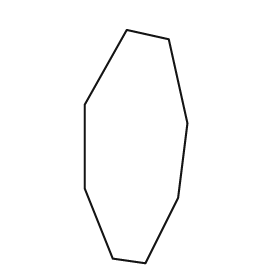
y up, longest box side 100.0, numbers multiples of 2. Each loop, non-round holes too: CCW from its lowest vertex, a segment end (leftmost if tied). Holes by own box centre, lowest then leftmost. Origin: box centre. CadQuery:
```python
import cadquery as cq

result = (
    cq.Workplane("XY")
    .moveTo(4.0, -50.0)
    .lineTo(18.0, -22.0)
    .lineTo(22.0, 10.0)
    .lineTo(14.0, 46.0)
    .lineTo(-4.0, 50.0)
    .lineTo(-22.0, 18.0)
    .lineTo(-22.0, -18.0)
    .lineTo(-10.0, -48.0)
    .close()
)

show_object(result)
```